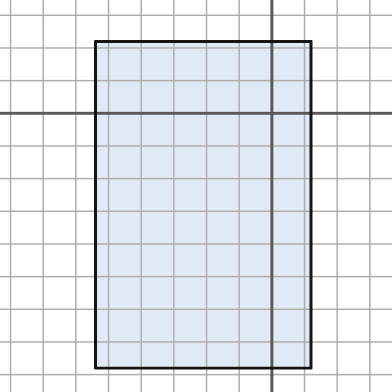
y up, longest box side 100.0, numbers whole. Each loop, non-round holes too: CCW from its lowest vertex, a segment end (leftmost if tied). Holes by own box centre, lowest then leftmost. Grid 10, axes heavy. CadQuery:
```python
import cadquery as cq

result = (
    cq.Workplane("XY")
    .moveTo(-54.0, -78.0)
    .lineTo(12.0, -78.0)
    .lineTo(12.0, 22.0)
    .lineTo(-54.0, 22.0)
    .close()
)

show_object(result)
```